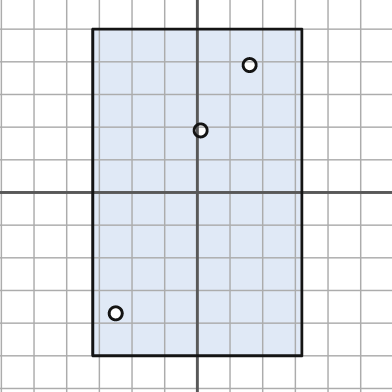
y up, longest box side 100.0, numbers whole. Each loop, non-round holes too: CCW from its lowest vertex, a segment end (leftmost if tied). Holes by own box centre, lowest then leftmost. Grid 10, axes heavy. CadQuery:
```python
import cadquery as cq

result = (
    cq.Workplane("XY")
    .moveTo(-32.0, -50.0)
    .lineTo(32.0, -50.0)
    .lineTo(32.0, 50.0)
    .lineTo(-32.0, 50.0)
    .close()
    .moveTo(-25.0, -37.0)
    .circle(2.0)
    .moveTo(1.0, 19.0)
    .circle(2.0)
    .moveTo(16.0, 39.0)
    .circle(2.0)
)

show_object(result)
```